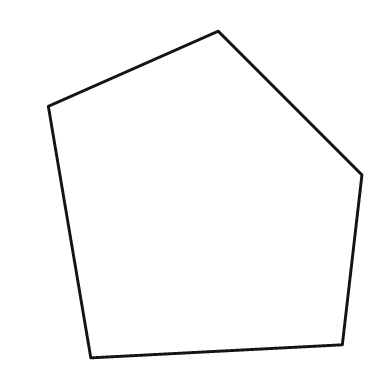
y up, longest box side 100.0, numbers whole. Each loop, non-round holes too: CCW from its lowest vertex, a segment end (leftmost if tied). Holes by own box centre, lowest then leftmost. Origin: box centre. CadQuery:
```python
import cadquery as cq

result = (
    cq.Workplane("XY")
    .moveTo(-35.0, -50.0)
    .lineTo(42.0, -46.0)
    .lineTo(48.0, 6.0)
    .lineTo(4.0, 50.0)
    .lineTo(-48.0, 27.0)
    .close()
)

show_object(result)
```